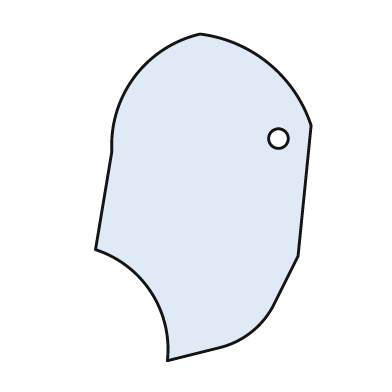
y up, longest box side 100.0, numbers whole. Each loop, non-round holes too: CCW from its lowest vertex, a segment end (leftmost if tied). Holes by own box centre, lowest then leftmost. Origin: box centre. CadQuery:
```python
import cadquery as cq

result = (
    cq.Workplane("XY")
    .moveTo(-11.0, -50.0)
    .lineTo(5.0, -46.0)
    .threePointArc((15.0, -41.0), (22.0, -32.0))
    .lineTo(29.0, -18.0)
    .lineTo(33.0, 22.0)
    .threePointArc((20.0, 41.0), (-1.0, 50.0))
    .threePointArc((-21.0, 37.0), (-28.0, 14.0))
    .lineTo(-33.0, -16.0)
    .threePointArc((-16.0, -29.0), (-11.0, -50.0))
    .close()
    .moveTo(23.0, 18.0)
    .circle(3.0)
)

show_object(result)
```